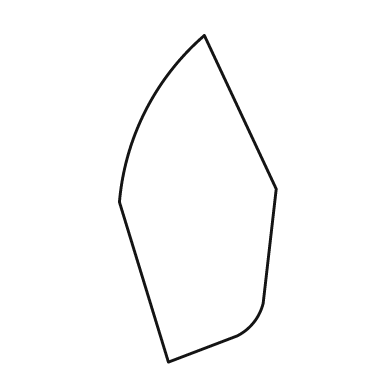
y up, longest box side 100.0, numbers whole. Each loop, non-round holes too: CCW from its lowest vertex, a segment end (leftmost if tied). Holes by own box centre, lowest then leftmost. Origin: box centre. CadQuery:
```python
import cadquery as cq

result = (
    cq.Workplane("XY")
    .moveTo(-9.0, -50.0)
    .lineTo(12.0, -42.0)
    .threePointArc((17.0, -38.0), (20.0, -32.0))
    .lineTo(24.0, 3.0)
    .lineTo(2.0, 50.0)
    .threePointArc((-16.0, 27.0), (-24.0, -1.0))
    .close()
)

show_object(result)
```